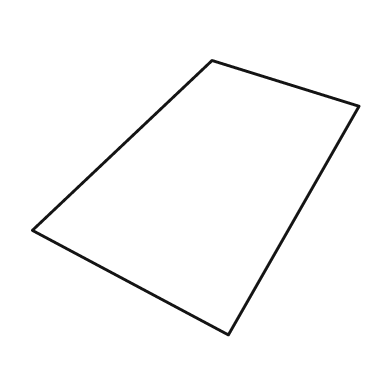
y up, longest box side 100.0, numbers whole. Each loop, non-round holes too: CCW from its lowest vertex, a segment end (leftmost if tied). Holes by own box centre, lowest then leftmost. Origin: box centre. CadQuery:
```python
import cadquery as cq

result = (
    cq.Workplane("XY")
    .moveTo(10.0, -42.0)
    .lineTo(50.0, 28.0)
    .lineTo(5.0, 42.0)
    .lineTo(-50.0, -10.0)
    .close()
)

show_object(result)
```